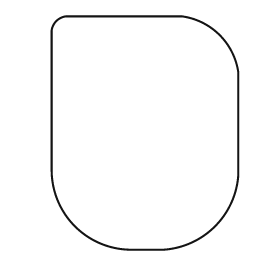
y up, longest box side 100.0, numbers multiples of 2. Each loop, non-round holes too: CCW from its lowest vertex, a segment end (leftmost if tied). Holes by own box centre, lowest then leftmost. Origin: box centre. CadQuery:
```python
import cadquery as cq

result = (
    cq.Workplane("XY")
    .moveTo(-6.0, -50.0)
    .lineTo(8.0, -50.0)
    .threePointArc((30.0, -40.0), (40.0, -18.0))
    .lineTo(40.0, 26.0)
    .threePointArc((32.0, 42.0), (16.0, 50.0))
    .lineTo(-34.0, 50.0)
    .threePointArc((-38.0, 48.0), (-40.0, 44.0))
    .lineTo(-40.0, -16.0)
    .threePointArc((-30.0, -40.0), (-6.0, -50.0))
    .close()
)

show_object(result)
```